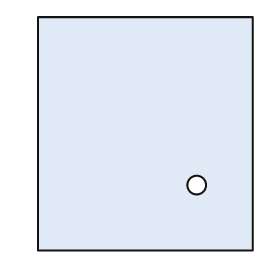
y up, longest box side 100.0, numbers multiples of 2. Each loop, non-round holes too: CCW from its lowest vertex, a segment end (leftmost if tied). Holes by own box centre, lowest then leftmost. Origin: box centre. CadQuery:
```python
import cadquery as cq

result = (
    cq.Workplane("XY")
    .moveTo(-46.0, -50.0)
    .lineTo(46.0, -50.0)
    .lineTo(46.0, 50.0)
    .lineTo(-46.0, 50.0)
    .close()
    .moveTo(22.0, -22.0)
    .circle(4.0)
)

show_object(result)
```